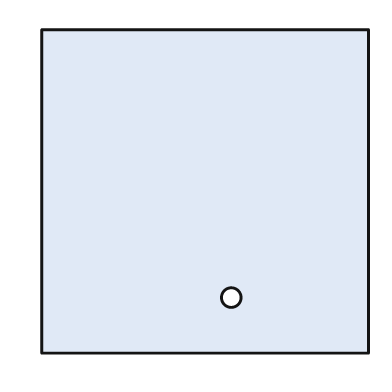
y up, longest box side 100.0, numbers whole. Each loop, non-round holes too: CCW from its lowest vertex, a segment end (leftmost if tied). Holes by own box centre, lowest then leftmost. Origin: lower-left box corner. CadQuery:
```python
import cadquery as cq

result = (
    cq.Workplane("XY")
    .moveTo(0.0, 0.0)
    .lineTo(100.0, 0.0)
    .lineTo(100.0, 99.0)
    .lineTo(0.0, 99.0)
    .close()
    .moveTo(58.0, 17.0)
    .circle(3.0)
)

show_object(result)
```